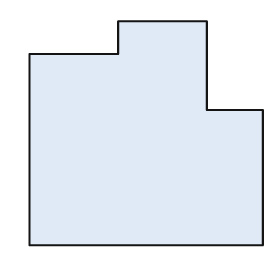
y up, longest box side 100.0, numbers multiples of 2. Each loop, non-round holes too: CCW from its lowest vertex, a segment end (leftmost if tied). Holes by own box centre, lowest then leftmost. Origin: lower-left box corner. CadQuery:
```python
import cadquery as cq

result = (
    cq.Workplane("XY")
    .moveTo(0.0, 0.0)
    .lineTo(100.0, 0.0)
    .lineTo(100.0, 58.0)
    .lineTo(76.0, 58.0)
    .lineTo(76.0, 96.0)
    .lineTo(38.0, 96.0)
    .lineTo(38.0, 82.0)
    .lineTo(0.0, 82.0)
    .close()
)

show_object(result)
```